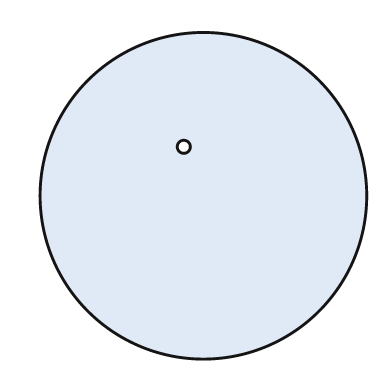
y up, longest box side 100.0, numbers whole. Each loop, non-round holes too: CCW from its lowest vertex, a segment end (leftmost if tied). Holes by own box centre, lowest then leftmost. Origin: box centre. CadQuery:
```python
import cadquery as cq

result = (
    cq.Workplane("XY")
    .moveTo(0.0, 0.0)
    .circle(50.0)
    .moveTo(-6.0, 15.0)
    .circle(2.0)
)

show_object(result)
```